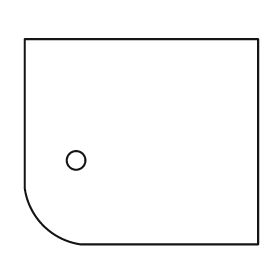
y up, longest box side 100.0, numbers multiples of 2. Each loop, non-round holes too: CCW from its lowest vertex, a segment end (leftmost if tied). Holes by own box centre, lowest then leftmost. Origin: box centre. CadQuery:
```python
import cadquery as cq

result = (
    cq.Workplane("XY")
    .moveTo(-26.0, -44.0)
    .lineTo(50.0, -44.0)
    .lineTo(50.0, 44.0)
    .lineTo(-50.0, 44.0)
    .lineTo(-50.0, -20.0)
    .threePointArc((-42.0, -36.0), (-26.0, -44.0))
    .close()
    .moveTo(-28.0, -8.0)
    .circle(4.0)
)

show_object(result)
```